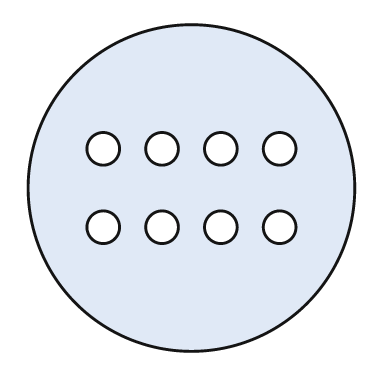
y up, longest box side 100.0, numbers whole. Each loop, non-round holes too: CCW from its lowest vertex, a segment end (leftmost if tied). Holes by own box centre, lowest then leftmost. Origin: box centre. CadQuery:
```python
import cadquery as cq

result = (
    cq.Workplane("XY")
    .moveTo(0.0, 0.0)
    .circle(50.0)
    .moveTo(-27.0, -12.0)
    .circle(5.0)
    .moveTo(-9.0, -12.0)
    .circle(5.0)
    .moveTo(9.0, -12.0)
    .circle(5.0)
    .moveTo(27.0, -12.0)
    .circle(5.0)
    .moveTo(-27.0, 12.0)
    .circle(5.0)
    .moveTo(-9.0, 12.0)
    .circle(5.0)
    .moveTo(9.0, 12.0)
    .circle(5.0)
    .moveTo(27.0, 12.0)
    .circle(5.0)
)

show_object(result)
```